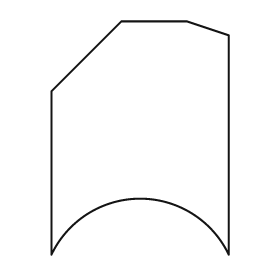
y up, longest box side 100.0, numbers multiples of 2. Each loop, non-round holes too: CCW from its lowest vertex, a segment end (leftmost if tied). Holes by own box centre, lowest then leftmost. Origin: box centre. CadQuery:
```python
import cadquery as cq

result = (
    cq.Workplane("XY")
    .moveTo(-38.0, -50.0)
    .threePointArc((0.0, -26.0), (38.0, -50.0))
    .lineTo(38.0, 44.0)
    .lineTo(20.0, 50.0)
    .lineTo(-8.0, 50.0)
    .lineTo(-38.0, 20.0)
    .close()
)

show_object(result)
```